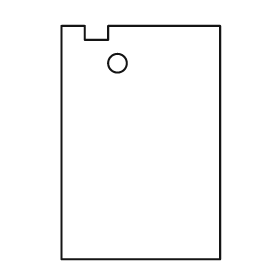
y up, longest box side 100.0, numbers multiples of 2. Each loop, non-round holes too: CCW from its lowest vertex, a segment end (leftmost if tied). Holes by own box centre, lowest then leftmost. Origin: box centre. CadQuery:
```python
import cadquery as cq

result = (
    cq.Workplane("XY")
    .moveTo(-34.0, -50.0)
    .lineTo(34.0, -50.0)
    .lineTo(34.0, 50.0)
    .lineTo(-14.0, 50.0)
    .lineTo(-14.0, 44.0)
    .lineTo(-24.0, 44.0)
    .lineTo(-24.0, 50.0)
    .lineTo(-34.0, 50.0)
    .close()
    .moveTo(-10.0, 34.0)
    .circle(4.0)
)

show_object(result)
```